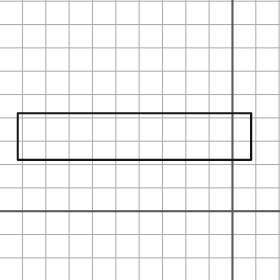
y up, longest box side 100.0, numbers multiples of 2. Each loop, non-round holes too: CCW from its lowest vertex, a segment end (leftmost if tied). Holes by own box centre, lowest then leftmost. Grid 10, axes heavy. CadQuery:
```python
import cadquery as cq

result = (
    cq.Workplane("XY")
    .moveTo(-92.0, 22.0)
    .lineTo(8.0, 22.0)
    .lineTo(8.0, 42.0)
    .lineTo(-92.0, 42.0)
    .close()
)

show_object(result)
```